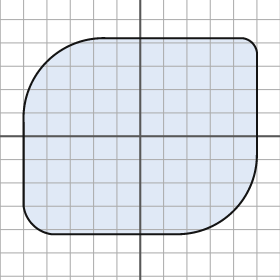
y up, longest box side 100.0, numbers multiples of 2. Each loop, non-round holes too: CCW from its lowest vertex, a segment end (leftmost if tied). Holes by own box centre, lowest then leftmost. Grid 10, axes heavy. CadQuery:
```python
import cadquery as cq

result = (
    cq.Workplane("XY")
    .moveTo(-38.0, -42.0)
    .lineTo(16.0, -42.0)
    .threePointArc((40.0, -32.0), (50.0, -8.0))
    .lineTo(50.0, 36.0)
    .threePointArc((48.0, 40.0), (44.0, 42.0))
    .lineTo(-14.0, 42.0)
    .threePointArc((-40.0, 32.0), (-50.0, 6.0))
    .lineTo(-50.0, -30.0)
    .threePointArc((-46.0, -38.0), (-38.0, -42.0))
    .close()
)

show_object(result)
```